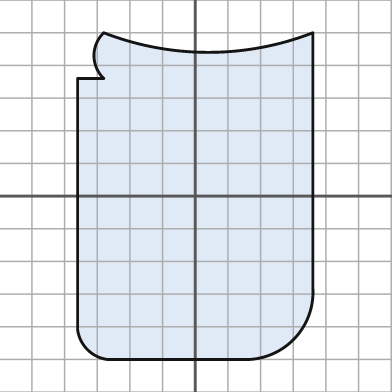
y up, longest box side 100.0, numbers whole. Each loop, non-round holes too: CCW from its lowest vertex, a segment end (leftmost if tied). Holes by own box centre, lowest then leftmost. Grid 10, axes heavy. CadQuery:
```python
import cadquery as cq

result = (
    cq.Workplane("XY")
    .moveTo(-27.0, -50.0)
    .lineTo(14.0, -50.0)
    .threePointArc((30.0, -44.0), (36.0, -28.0))
    .lineTo(36.0, 50.0)
    .threePointArc((4.0, 44.0), (-28.0, 50.0))
    .threePointArc((-31.0, 43.0), (-28.0, 36.0))
    .lineTo(-36.0, 36.0)
    .lineTo(-36.0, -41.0)
    .threePointArc((-33.0, -47.0), (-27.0, -50.0))
    .close()
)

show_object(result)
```